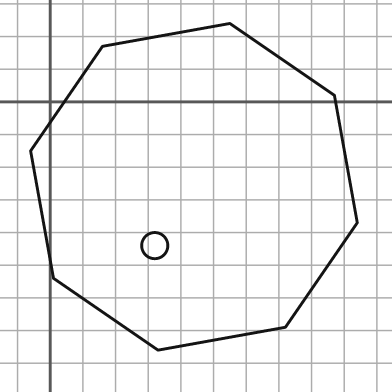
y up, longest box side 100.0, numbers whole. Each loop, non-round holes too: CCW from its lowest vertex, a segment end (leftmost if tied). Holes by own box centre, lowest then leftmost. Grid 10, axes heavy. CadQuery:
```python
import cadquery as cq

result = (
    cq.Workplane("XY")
    .moveTo(33.0, -76.0)
    .lineTo(72.0, -69.0)
    .lineTo(94.0, -37.0)
    .lineTo(87.0, 2.0)
    .lineTo(55.0, 24.0)
    .lineTo(16.0, 17.0)
    .lineTo(-6.0, -15.0)
    .lineTo(1.0, -54.0)
    .close()
    .moveTo(32.0, -44.0)
    .circle(4.0)
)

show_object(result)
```